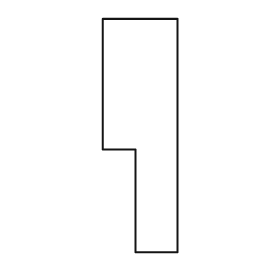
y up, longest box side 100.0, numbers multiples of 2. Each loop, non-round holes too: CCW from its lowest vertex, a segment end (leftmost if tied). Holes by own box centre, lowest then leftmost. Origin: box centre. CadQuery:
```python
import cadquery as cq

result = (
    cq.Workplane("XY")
    .moveTo(-2.0, -50.0)
    .lineTo(16.0, -50.0)
    .lineTo(16.0, 50.0)
    .lineTo(-16.0, 50.0)
    .lineTo(-16.0, -6.0)
    .lineTo(-2.0, -6.0)
    .close()
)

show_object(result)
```